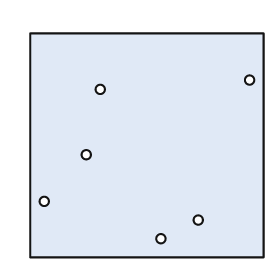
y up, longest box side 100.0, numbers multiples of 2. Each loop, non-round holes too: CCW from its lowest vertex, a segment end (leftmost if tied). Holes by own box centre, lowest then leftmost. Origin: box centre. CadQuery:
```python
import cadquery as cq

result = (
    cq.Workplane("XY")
    .moveTo(-50.0, -48.0)
    .lineTo(50.0, -48.0)
    .lineTo(50.0, 48.0)
    .lineTo(-50.0, 48.0)
    .close()
    .moveTo(6.0, -40.0)
    .circle(2.0)
    .moveTo(22.0, -32.0)
    .circle(2.0)
    .moveTo(-44.0, -24.0)
    .circle(2.0)
    .moveTo(-26.0, -4.0)
    .circle(2.0)
    .moveTo(-20.0, 24.0)
    .circle(2.0)
    .moveTo(44.0, 28.0)
    .circle(2.0)
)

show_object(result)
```